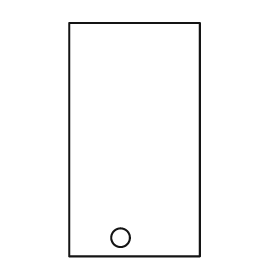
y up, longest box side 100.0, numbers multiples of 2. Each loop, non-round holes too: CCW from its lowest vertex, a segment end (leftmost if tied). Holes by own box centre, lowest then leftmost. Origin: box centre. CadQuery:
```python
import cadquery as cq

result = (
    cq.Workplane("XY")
    .moveTo(-28.0, -50.0)
    .lineTo(28.0, -50.0)
    .lineTo(28.0, 50.0)
    .lineTo(-28.0, 50.0)
    .close()
    .moveTo(-6.0, -42.0)
    .circle(4.0)
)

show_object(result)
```